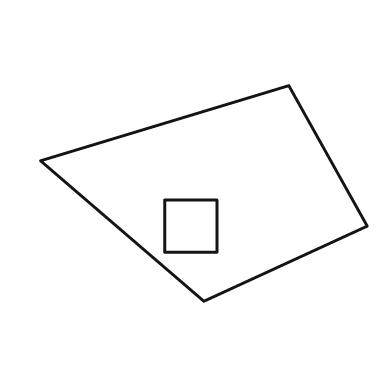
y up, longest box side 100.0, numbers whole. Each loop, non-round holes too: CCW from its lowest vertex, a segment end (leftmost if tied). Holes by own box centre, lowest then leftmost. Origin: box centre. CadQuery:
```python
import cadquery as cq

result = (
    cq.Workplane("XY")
    .moveTo(0.0, -33.0)
    .lineTo(50.0, -10.0)
    .lineTo(26.0, 33.0)
    .lineTo(-50.0, 10.0)
    .close()
    .moveTo(-12.0, -18.0)
    .lineTo(4.0, -18.0)
    .lineTo(4.0, -2.0)
    .lineTo(-12.0, -2.0)
    .close()
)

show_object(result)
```